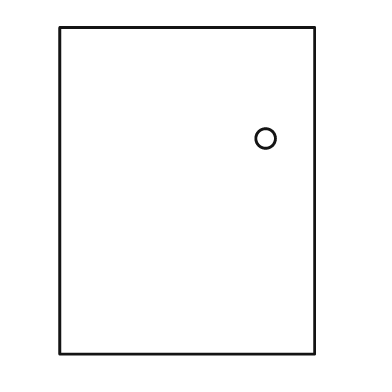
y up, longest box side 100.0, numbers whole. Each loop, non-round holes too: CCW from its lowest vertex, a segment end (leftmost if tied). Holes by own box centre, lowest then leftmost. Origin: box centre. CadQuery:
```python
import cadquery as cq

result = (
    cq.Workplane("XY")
    .moveTo(-39.0, -50.0)
    .lineTo(39.0, -50.0)
    .lineTo(39.0, 50.0)
    .lineTo(-39.0, 50.0)
    .close()
    .moveTo(24.0, 16.0)
    .circle(3.0)
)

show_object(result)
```